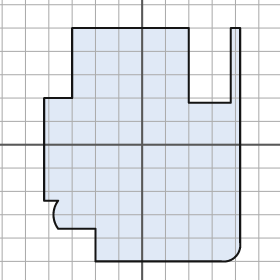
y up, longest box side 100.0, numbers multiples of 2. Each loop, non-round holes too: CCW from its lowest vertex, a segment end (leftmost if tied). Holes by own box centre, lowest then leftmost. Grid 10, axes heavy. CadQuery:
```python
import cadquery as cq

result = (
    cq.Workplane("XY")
    .moveTo(-20.0, -50.0)
    .lineTo(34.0, -50.0)
    .threePointArc((40.0, -48.0), (42.0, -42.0))
    .lineTo(42.0, 50.0)
    .lineTo(38.0, 50.0)
    .lineTo(38.0, 18.0)
    .lineTo(20.0, 18.0)
    .lineTo(20.0, 50.0)
    .lineTo(-30.0, 50.0)
    .lineTo(-30.0, 20.0)
    .lineTo(-42.0, 20.0)
    .lineTo(-42.0, -24.0)
    .lineTo(-36.0, -24.0)
    .threePointArc((-38.0, -30.0), (-36.0, -36.0))
    .lineTo(-20.0, -36.0)
    .close()
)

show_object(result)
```